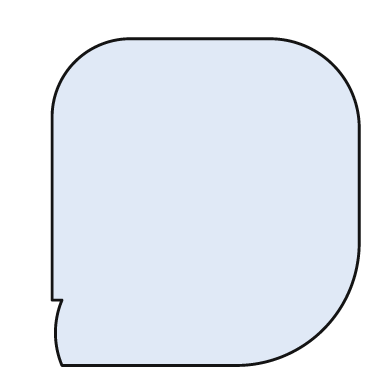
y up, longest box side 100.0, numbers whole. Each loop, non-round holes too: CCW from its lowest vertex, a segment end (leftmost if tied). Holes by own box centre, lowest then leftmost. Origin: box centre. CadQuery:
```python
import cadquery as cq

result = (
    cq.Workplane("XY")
    .moveTo(-44.0, -50.0)
    .lineTo(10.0, -50.0)
    .threePointArc((36.0, -39.0), (47.0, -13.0))
    .lineTo(47.0, 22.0)
    .threePointArc((39.0, 42.0), (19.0, 50.0))
    .lineTo(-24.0, 50.0)
    .threePointArc((-40.0, 43.0), (-47.0, 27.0))
    .lineTo(-47.0, -30.0)
    .lineTo(-44.0, -30.0)
    .threePointArc((-46.0, -40.0), (-44.0, -50.0))
    .close()
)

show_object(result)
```